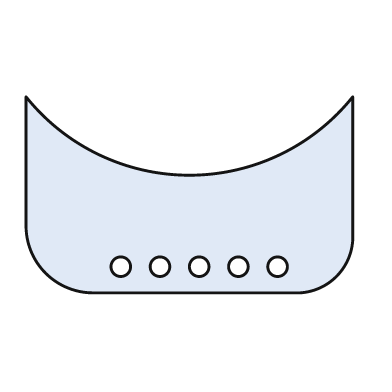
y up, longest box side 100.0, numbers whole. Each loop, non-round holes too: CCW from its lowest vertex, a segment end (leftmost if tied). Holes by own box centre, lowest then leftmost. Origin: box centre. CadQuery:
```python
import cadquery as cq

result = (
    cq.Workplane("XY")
    .moveTo(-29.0, -30.0)
    .lineTo(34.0, -30.0)
    .threePointArc((45.0, -25.0), (50.0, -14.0))
    .lineTo(50.0, 30.0)
    .threePointArc((0.0, 6.0), (-50.0, 30.0))
    .lineTo(-50.0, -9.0)
    .threePointArc((-44.0, -24.0), (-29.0, -30.0))
    .close()
    .moveTo(-21.0, -22.0)
    .circle(3.0)
    .moveTo(-9.0, -22.0)
    .circle(3.0)
    .moveTo(3.0, -22.0)
    .circle(3.0)
    .moveTo(15.0, -22.0)
    .circle(3.0)
    .moveTo(27.0, -22.0)
    .circle(3.0)
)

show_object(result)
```